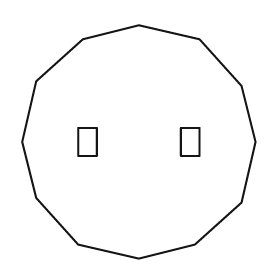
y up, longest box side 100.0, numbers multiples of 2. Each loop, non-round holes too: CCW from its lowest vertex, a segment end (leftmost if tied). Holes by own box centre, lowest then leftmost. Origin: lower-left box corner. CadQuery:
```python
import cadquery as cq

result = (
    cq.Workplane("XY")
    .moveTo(50.0, 0.0)
    .lineTo(74.0, 6.0)
    .lineTo(94.0, 24.0)
    .lineTo(100.0, 50.0)
    .lineTo(94.0, 74.0)
    .lineTo(76.0, 94.0)
    .lineTo(50.0, 100.0)
    .lineTo(26.0, 94.0)
    .lineTo(6.0, 76.0)
    .lineTo(0.0, 50.0)
    .lineTo(6.0, 26.0)
    .lineTo(24.0, 6.0)
    .close()
    .moveTo(24.0, 44.0)
    .lineTo(32.0, 44.0)
    .lineTo(32.0, 56.0)
    .lineTo(24.0, 56.0)
    .close()
    .moveTo(68.0, 44.0)
    .lineTo(76.0, 44.0)
    .lineTo(76.0, 56.0)
    .lineTo(68.0, 56.0)
    .close()
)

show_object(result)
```